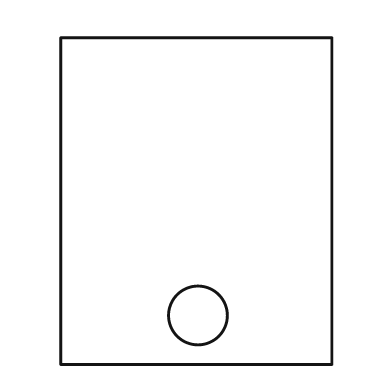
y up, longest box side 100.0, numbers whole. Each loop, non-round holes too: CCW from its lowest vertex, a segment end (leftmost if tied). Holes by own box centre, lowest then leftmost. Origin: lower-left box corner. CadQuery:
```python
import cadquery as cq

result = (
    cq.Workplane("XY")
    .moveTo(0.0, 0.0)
    .lineTo(83.0, 0.0)
    .lineTo(83.0, 100.0)
    .lineTo(0.0, 100.0)
    .close()
    .moveTo(42.0, 15.0)
    .circle(9.0)
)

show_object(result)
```